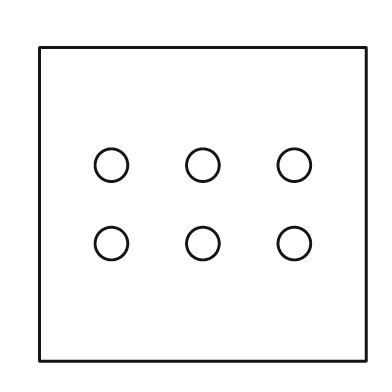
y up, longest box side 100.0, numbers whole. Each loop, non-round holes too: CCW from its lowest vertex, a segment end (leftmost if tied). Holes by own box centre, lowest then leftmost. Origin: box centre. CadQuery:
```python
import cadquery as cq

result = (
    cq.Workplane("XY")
    .moveTo(-50.0, -48.0)
    .lineTo(50.0, -48.0)
    .lineTo(50.0, 48.0)
    .lineTo(-50.0, 48.0)
    .close()
    .moveTo(-28.0, -12.0)
    .circle(5.0)
    .moveTo(0.0, -12.0)
    .circle(5.0)
    .moveTo(28.0, -12.0)
    .circle(5.0)
    .moveTo(-28.0, 12.0)
    .circle(5.0)
    .moveTo(0.0, 12.0)
    .circle(5.0)
    .moveTo(28.0, 12.0)
    .circle(5.0)
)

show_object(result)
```